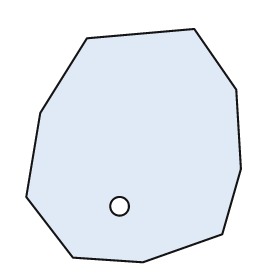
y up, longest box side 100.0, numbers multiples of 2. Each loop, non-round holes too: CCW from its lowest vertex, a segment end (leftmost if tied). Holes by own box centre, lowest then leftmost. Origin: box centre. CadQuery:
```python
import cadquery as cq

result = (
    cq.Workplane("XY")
    .moveTo(4.0, -50.0)
    .lineTo(38.0, -38.0)
    .lineTo(46.0, -10.0)
    .lineTo(44.0, 24.0)
    .lineTo(26.0, 50.0)
    .lineTo(-20.0, 46.0)
    .lineTo(-40.0, 14.0)
    .lineTo(-46.0, -22.0)
    .lineTo(-26.0, -48.0)
    .close()
    .moveTo(-6.0, -26.0)
    .circle(4.0)
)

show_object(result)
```